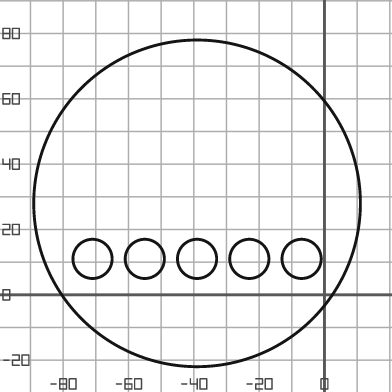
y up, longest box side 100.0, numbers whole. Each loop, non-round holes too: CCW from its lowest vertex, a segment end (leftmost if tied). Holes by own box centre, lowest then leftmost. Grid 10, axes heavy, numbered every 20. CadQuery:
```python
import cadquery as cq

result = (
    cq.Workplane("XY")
    .moveTo(-39.0, 28.0)
    .circle(50.0)
    .moveTo(-71.0, 11.0)
    .circle(6.0)
    .moveTo(-55.0, 11.0)
    .circle(6.0)
    .moveTo(-39.0, 11.0)
    .circle(6.0)
    .moveTo(-23.0, 11.0)
    .circle(6.0)
    .moveTo(-7.0, 11.0)
    .circle(6.0)
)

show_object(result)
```